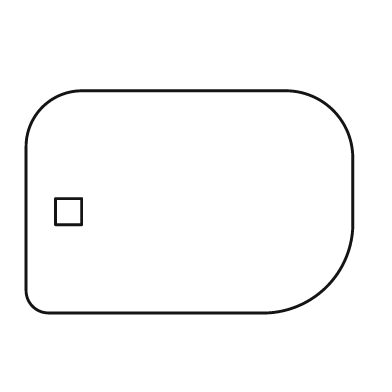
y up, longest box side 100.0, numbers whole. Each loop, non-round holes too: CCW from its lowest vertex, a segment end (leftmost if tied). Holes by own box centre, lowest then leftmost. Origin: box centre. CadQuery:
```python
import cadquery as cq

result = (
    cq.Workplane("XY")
    .moveTo(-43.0, -34.0)
    .lineTo(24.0, -34.0)
    .threePointArc((42.0, -26.0), (50.0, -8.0))
    .lineTo(50.0, 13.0)
    .threePointArc((44.0, 28.0), (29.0, 34.0))
    .lineTo(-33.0, 34.0)
    .threePointArc((-45.0, 29.0), (-50.0, 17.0))
    .lineTo(-50.0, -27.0)
    .threePointArc((-48.0, -32.0), (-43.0, -34.0))
    .close()
    .moveTo(-41.0, -7.0)
    .lineTo(-33.0, -7.0)
    .lineTo(-33.0, 1.0)
    .lineTo(-41.0, 1.0)
    .close()
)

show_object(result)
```